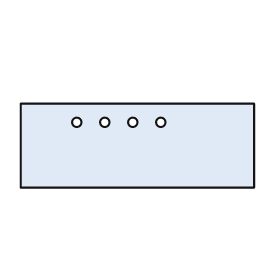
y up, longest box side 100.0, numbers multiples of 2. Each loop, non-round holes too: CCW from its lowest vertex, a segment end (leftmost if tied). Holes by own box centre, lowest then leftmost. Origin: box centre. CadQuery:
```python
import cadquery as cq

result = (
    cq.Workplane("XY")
    .moveTo(-50.0, -18.0)
    .lineTo(50.0, -18.0)
    .lineTo(50.0, 18.0)
    .lineTo(-50.0, 18.0)
    .close()
    .moveTo(-26.0, 10.0)
    .circle(2.0)
    .moveTo(-14.0, 10.0)
    .circle(2.0)
    .moveTo(-2.0, 10.0)
    .circle(2.0)
    .moveTo(10.0, 10.0)
    .circle(2.0)
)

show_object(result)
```